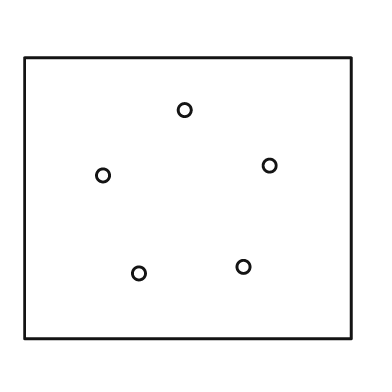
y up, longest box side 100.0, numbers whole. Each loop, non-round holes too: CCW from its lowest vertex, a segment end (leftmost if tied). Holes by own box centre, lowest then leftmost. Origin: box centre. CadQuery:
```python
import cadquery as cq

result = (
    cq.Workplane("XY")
    .moveTo(-50.0, -43.0)
    .lineTo(50.0, -43.0)
    .lineTo(50.0, 43.0)
    .lineTo(-50.0, 43.0)
    .close()
    .moveTo(-15.0, -23.0)
    .circle(2.0)
    .moveTo(17.0, -21.0)
    .circle(2.0)
    .moveTo(-26.0, 7.0)
    .circle(2.0)
    .moveTo(25.0, 10.0)
    .circle(2.0)
    .moveTo(-1.0, 27.0)
    .circle(2.0)
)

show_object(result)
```